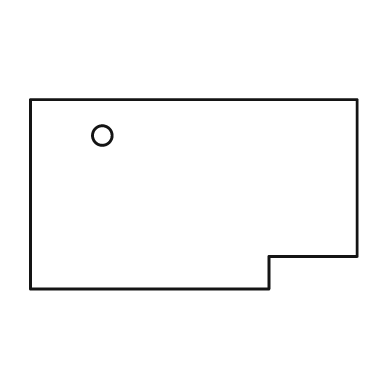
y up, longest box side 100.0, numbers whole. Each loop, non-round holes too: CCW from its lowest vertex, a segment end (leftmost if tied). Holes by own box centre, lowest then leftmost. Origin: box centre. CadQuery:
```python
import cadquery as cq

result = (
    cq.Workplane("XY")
    .moveTo(-50.0, -29.0)
    .lineTo(23.0, -29.0)
    .lineTo(23.0, -19.0)
    .lineTo(50.0, -19.0)
    .lineTo(50.0, 29.0)
    .lineTo(-50.0, 29.0)
    .close()
    .moveTo(-28.0, 18.0)
    .circle(3.0)
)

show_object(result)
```